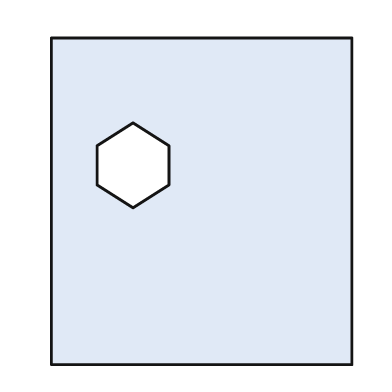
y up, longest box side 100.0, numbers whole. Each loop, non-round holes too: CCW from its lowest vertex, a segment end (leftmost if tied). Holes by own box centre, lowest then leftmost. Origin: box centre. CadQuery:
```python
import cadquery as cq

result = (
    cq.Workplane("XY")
    .moveTo(-46.0, -50.0)
    .lineTo(46.0, -50.0)
    .lineTo(46.0, 50.0)
    .lineTo(-46.0, 50.0)
    .close()
    .moveTo(-21.0, -2.0)
    .lineTo(-10.0, 5.0)
    .lineTo(-10.0, 17.0)
    .lineTo(-21.0, 24.0)
    .lineTo(-32.0, 17.0)
    .lineTo(-32.0, 5.0)
    .close()
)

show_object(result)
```